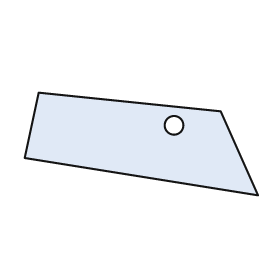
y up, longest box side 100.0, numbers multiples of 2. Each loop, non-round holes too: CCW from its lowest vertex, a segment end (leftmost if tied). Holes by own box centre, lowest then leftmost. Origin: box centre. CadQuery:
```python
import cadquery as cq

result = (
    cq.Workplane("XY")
    .moveTo(50.0, -22.0)
    .lineTo(34.0, 14.0)
    .lineTo(-44.0, 22.0)
    .lineTo(-50.0, -6.0)
    .close()
    .moveTo(14.0, 8.0)
    .circle(4.0)
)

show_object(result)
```